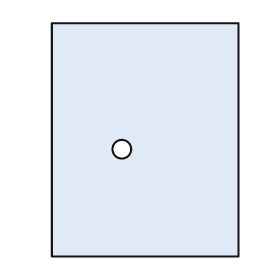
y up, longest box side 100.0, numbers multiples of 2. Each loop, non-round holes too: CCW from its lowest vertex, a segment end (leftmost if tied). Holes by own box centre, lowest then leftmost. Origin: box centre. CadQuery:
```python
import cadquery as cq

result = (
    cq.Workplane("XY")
    .moveTo(-40.0, -50.0)
    .lineTo(40.0, -50.0)
    .lineTo(40.0, 50.0)
    .lineTo(-40.0, 50.0)
    .close()
    .moveTo(-10.0, -4.0)
    .circle(4.0)
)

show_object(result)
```